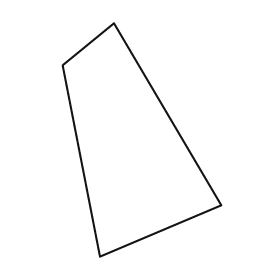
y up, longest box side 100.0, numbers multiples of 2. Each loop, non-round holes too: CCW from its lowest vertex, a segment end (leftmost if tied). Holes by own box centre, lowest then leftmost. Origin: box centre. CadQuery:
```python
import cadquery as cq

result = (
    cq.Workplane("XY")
    .moveTo(-18.0, -50.0)
    .lineTo(34.0, -28.0)
    .lineTo(-12.0, 50.0)
    .lineTo(-34.0, 32.0)
    .close()
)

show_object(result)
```